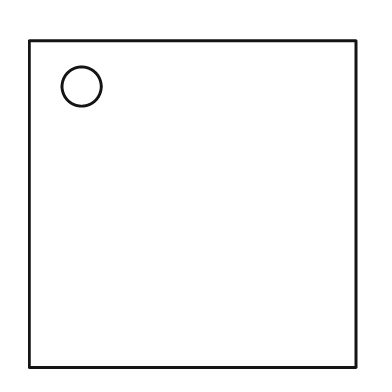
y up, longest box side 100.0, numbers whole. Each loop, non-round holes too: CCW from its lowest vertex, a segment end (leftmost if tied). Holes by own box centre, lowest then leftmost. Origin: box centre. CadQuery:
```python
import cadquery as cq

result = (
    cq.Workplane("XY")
    .moveTo(-50.0, -50.0)
    .lineTo(50.0, -50.0)
    .lineTo(50.0, 50.0)
    .lineTo(-50.0, 50.0)
    .close()
    .moveTo(-34.0, 36.0)
    .circle(6.0)
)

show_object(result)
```